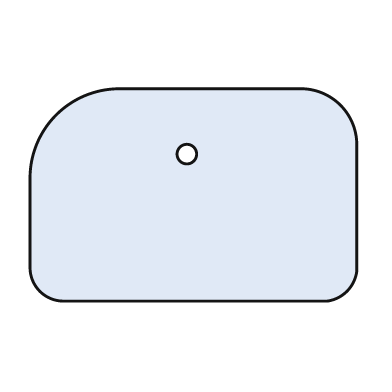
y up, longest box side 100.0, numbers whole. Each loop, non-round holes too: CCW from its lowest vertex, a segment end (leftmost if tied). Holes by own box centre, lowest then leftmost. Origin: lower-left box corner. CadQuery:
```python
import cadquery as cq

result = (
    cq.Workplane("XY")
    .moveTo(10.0, 0.0)
    .lineTo(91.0, 0.0)
    .threePointArc((97.0, 3.0), (100.0, 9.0))
    .lineTo(100.0, 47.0)
    .threePointArc((95.0, 60.0), (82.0, 65.0))
    .lineTo(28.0, 65.0)
    .threePointArc((8.0, 57.0), (0.0, 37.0))
    .lineTo(0.0, 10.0)
    .threePointArc((3.0, 3.0), (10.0, 0.0))
    .close()
    .moveTo(48.0, 45.0)
    .circle(3.0)
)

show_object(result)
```